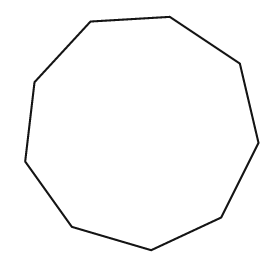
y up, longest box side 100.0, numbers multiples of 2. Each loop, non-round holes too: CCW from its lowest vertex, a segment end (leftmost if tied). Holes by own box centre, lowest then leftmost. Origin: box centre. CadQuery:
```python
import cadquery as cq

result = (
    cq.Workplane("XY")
    .moveTo(4.0, -50.0)
    .lineTo(34.0, -36.0)
    .lineTo(50.0, -4.0)
    .lineTo(42.0, 30.0)
    .lineTo(12.0, 50.0)
    .lineTo(-22.0, 48.0)
    .lineTo(-46.0, 22.0)
    .lineTo(-50.0, -12.0)
    .lineTo(-30.0, -40.0)
    .close()
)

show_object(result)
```